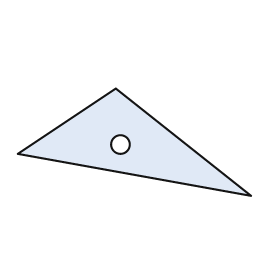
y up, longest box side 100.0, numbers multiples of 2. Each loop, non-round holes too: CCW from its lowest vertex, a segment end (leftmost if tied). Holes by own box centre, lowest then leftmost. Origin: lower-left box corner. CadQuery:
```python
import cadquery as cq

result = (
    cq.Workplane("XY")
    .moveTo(100.0, 0.0)
    .lineTo(42.0, 46.0)
    .lineTo(0.0, 18.0)
    .close()
    .moveTo(44.0, 22.0)
    .circle(4.0)
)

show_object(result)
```